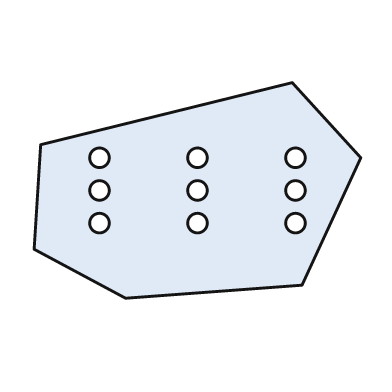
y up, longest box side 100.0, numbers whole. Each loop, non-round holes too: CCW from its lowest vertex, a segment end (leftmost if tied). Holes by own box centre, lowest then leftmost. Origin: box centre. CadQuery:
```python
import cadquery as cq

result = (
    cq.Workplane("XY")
    .moveTo(-22.0, -33.0)
    .lineTo(32.0, -29.0)
    .lineTo(50.0, 10.0)
    .lineTo(29.0, 33.0)
    .lineTo(-48.0, 14.0)
    .lineTo(-50.0, -18.0)
    .close()
    .moveTo(-30.0, -10.0)
    .circle(3.0)
    .moveTo(0.0, -10.0)
    .circle(3.0)
    .moveTo(30.0, -10.0)
    .circle(3.0)
    .moveTo(-30.0, 0.0)
    .circle(3.0)
    .moveTo(0.0, 0.0)
    .circle(3.0)
    .moveTo(30.0, 0.0)
    .circle(3.0)
    .moveTo(-30.0, 10.0)
    .circle(3.0)
    .moveTo(0.0, 10.0)
    .circle(3.0)
    .moveTo(30.0, 10.0)
    .circle(3.0)
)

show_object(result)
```